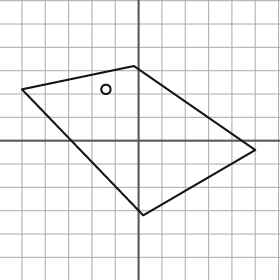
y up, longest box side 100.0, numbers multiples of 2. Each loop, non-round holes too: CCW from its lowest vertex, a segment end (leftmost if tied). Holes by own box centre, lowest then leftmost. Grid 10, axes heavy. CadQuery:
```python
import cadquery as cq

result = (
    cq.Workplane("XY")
    .moveTo(2.0, -32.0)
    .lineTo(50.0, -4.0)
    .lineTo(-2.0, 32.0)
    .lineTo(-50.0, 22.0)
    .close()
    .moveTo(-14.0, 22.0)
    .circle(2.0)
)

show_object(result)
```